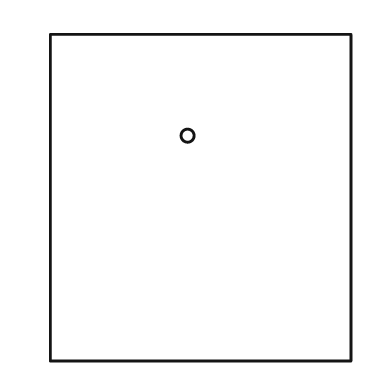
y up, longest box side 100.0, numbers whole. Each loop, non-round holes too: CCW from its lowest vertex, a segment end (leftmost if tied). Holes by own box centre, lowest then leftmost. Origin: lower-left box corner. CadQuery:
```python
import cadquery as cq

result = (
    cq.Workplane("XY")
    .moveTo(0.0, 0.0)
    .lineTo(92.0, 0.0)
    .lineTo(92.0, 100.0)
    .lineTo(0.0, 100.0)
    .close()
    .moveTo(42.0, 69.0)
    .circle(2.0)
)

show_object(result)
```